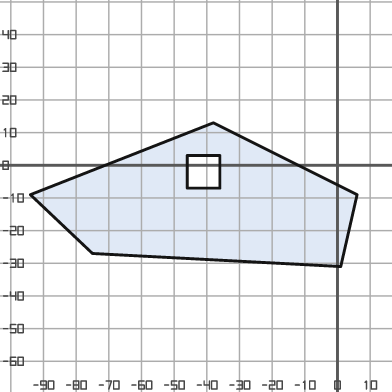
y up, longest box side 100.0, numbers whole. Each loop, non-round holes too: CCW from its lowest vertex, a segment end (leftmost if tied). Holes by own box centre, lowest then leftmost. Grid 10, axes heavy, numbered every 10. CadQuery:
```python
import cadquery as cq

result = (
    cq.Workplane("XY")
    .moveTo(1.0, -31.0)
    .lineTo(6.0, -9.0)
    .lineTo(-38.0, 13.0)
    .lineTo(-94.0, -9.0)
    .lineTo(-75.0, -27.0)
    .close()
    .moveTo(-46.0, -7.0)
    .lineTo(-36.0, -7.0)
    .lineTo(-36.0, 3.0)
    .lineTo(-46.0, 3.0)
    .close()
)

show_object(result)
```